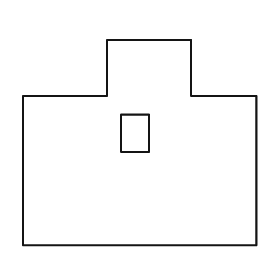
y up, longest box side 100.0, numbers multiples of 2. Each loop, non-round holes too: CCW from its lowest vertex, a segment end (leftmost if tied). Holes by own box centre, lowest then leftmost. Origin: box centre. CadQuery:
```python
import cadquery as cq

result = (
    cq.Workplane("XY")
    .moveTo(-50.0, -44.0)
    .lineTo(50.0, -44.0)
    .lineTo(50.0, 20.0)
    .lineTo(22.0, 20.0)
    .lineTo(22.0, 44.0)
    .lineTo(-14.0, 44.0)
    .lineTo(-14.0, 20.0)
    .lineTo(-50.0, 20.0)
    .close()
    .moveTo(-8.0, -4.0)
    .lineTo(4.0, -4.0)
    .lineTo(4.0, 12.0)
    .lineTo(-8.0, 12.0)
    .close()
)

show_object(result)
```